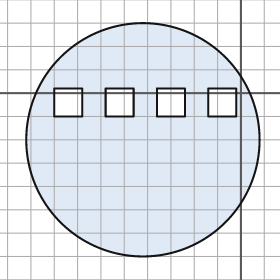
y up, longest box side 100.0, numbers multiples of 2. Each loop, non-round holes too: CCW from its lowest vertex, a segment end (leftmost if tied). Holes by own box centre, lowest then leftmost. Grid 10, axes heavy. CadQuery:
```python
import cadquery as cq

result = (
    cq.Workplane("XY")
    .moveTo(-42.0, -20.0)
    .circle(50.0)
    .moveTo(-80.0, -10.0)
    .lineTo(-68.0, -10.0)
    .lineTo(-68.0, 2.0)
    .lineTo(-80.0, 2.0)
    .close()
    .moveTo(-58.0, -10.0)
    .lineTo(-46.0, -10.0)
    .lineTo(-46.0, 2.0)
    .lineTo(-58.0, 2.0)
    .close()
    .moveTo(-36.0, -10.0)
    .lineTo(-24.0, -10.0)
    .lineTo(-24.0, 2.0)
    .lineTo(-36.0, 2.0)
    .close()
    .moveTo(-14.0, -10.0)
    .lineTo(-2.0, -10.0)
    .lineTo(-2.0, 2.0)
    .lineTo(-14.0, 2.0)
    .close()
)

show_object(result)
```